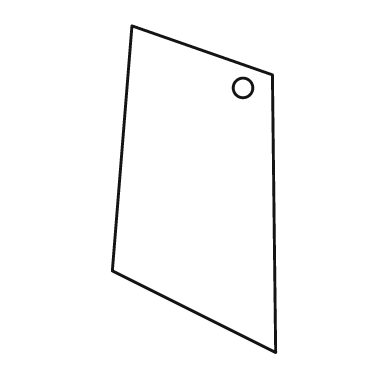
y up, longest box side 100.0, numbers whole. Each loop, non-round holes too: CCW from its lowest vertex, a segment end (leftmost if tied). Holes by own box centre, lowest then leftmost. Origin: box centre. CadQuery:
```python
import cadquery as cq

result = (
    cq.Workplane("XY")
    .moveTo(25.0, -50.0)
    .lineTo(24.0, 35.0)
    .lineTo(-19.0, 50.0)
    .lineTo(-25.0, -25.0)
    .close()
    .moveTo(15.0, 31.0)
    .circle(3.0)
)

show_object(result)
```